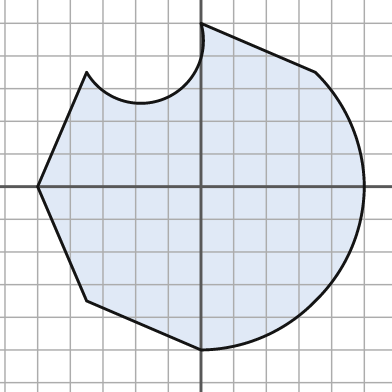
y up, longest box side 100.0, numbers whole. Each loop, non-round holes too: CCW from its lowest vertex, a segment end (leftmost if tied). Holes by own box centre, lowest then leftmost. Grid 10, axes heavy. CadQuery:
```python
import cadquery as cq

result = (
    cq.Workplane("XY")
    .moveTo(0.0, -50.0)
    .threePointArc((19.0, -46.0), (35.0, -35.0))
    .threePointArc((46.0, -19.0), (50.0, 0.0))
    .threePointArc((46.0, 19.0), (35.0, 35.0))
    .lineTo(0.0, 50.0)
    .threePointArc((-11.0, 27.0), (-35.0, 35.0))
    .lineTo(-50.0, 0.0)
    .lineTo(-35.0, -35.0)
    .close()
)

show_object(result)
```